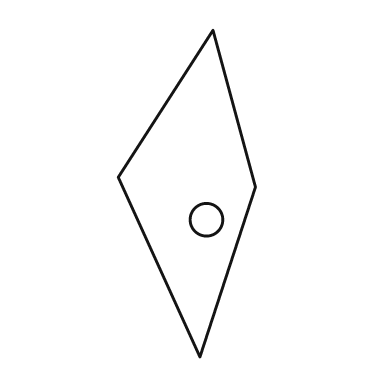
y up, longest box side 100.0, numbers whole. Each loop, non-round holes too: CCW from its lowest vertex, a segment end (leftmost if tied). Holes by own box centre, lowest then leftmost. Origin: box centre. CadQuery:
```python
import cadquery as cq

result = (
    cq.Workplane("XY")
    .moveTo(4.0, -50.0)
    .lineTo(21.0, 2.0)
    .lineTo(8.0, 50.0)
    .lineTo(-21.0, 5.0)
    .close()
    .moveTo(6.0, -8.0)
    .circle(5.0)
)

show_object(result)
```